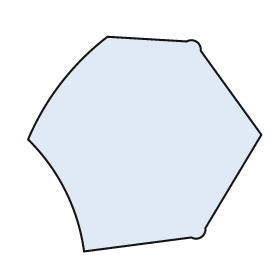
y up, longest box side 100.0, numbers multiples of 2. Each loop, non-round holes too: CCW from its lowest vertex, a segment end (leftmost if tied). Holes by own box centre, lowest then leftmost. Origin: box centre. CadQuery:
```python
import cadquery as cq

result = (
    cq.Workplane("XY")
    .moveTo(-26.0, -46.0)
    .lineTo(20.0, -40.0)
    .threePointArc((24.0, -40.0), (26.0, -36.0))
    .lineTo(50.0, 4.0)
    .lineTo(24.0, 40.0)
    .threePointArc((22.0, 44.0), (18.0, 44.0))
    .lineTo(-16.0, 46.0)
    .threePointArc((-36.0, 26.0), (-50.0, 2.0))
    .threePointArc((-34.0, -20.0), (-26.0, -46.0))
    .close()
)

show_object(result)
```